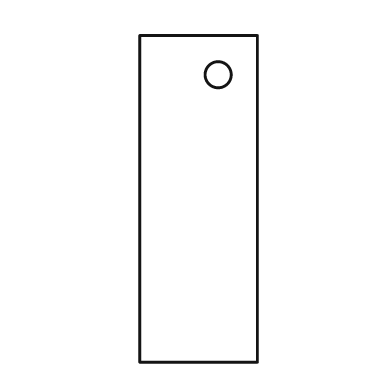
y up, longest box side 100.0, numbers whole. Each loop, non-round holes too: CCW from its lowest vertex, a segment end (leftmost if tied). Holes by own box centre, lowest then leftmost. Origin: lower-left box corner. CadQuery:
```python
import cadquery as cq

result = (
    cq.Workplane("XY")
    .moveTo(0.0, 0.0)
    .lineTo(36.0, 0.0)
    .lineTo(36.0, 100.0)
    .lineTo(0.0, 100.0)
    .close()
    .moveTo(24.0, 88.0)
    .circle(4.0)
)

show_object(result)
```